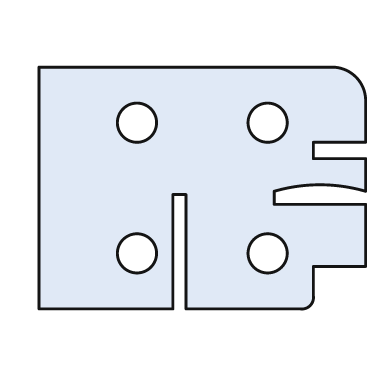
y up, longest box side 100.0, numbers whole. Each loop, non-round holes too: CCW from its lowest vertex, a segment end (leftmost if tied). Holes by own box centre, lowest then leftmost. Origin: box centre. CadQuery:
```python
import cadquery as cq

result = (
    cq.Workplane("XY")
    .moveTo(-50.0, -37.0)
    .lineTo(-9.0, -37.0)
    .lineTo(-9.0, -2.0)
    .lineTo(-5.0, -2.0)
    .lineTo(-5.0, -37.0)
    .lineTo(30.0, -37.0)
    .threePointArc((33.0, -36.0), (34.0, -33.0))
    .lineTo(34.0, -24.0)
    .lineTo(50.0, -24.0)
    .lineTo(50.0, -5.0)
    .lineTo(22.0, -5.0)
    .lineTo(22.0, -1.0)
    .threePointArc((36.0, 1.0), (50.0, -1.0))
    .lineTo(50.0, 9.0)
    .lineTo(34.0, 9.0)
    .lineTo(34.0, 14.0)
    .lineTo(50.0, 14.0)
    .lineTo(50.0, 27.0)
    .threePointArc((47.0, 34.0), (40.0, 37.0))
    .lineTo(-50.0, 37.0)
    .close()
    .moveTo(-20.0, -20.0)
    .circle(6.0)
    .moveTo(20.0, -20.0)
    .circle(6.0)
    .moveTo(-20.0, 20.0)
    .circle(6.0)
    .moveTo(20.0, 20.0)
    .circle(6.0)
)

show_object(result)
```